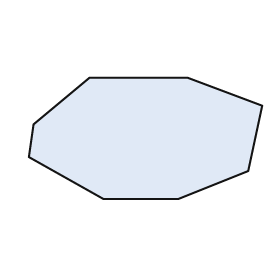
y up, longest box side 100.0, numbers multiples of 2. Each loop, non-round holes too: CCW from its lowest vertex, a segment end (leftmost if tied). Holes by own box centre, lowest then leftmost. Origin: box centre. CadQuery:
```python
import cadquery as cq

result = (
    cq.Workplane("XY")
    .moveTo(-18.0, -26.0)
    .lineTo(14.0, -26.0)
    .lineTo(44.0, -14.0)
    .lineTo(50.0, 14.0)
    .lineTo(18.0, 26.0)
    .lineTo(-24.0, 26.0)
    .lineTo(-48.0, 6.0)
    .lineTo(-50.0, -8.0)
    .close()
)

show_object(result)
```